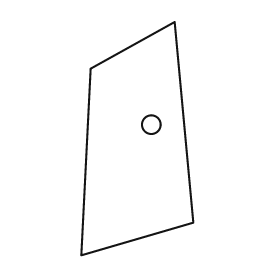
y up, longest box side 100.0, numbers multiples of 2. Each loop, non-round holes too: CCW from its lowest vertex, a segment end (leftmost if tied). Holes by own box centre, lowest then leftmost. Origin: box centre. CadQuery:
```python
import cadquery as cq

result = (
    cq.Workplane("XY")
    .moveTo(-24.0, -50.0)
    .lineTo(24.0, -36.0)
    .lineTo(16.0, 50.0)
    .lineTo(-20.0, 30.0)
    .close()
    .moveTo(6.0, 6.0)
    .circle(4.0)
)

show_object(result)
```